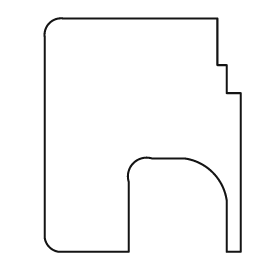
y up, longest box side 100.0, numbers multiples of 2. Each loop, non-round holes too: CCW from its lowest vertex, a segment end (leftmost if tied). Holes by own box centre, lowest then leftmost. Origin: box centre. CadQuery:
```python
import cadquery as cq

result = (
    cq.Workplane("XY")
    .moveTo(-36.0, -50.0)
    .lineTo(-6.0, -50.0)
    .lineTo(-6.0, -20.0)
    .threePointArc((-4.0, -12.0), (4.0, -10.0))
    .lineTo(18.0, -10.0)
    .threePointArc((30.0, -16.0), (36.0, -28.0))
    .lineTo(36.0, -50.0)
    .lineTo(42.0, -50.0)
    .lineTo(42.0, 18.0)
    .lineTo(36.0, 18.0)
    .lineTo(36.0, 30.0)
    .lineTo(32.0, 30.0)
    .lineTo(32.0, 50.0)
    .lineTo(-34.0, 50.0)
    .threePointArc((-40.0, 48.0), (-42.0, 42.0))
    .lineTo(-42.0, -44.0)
    .threePointArc((-40.0, -48.0), (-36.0, -50.0))
    .close()
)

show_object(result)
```